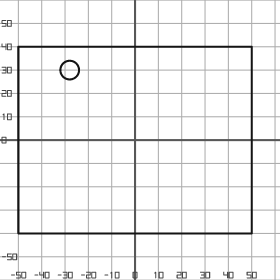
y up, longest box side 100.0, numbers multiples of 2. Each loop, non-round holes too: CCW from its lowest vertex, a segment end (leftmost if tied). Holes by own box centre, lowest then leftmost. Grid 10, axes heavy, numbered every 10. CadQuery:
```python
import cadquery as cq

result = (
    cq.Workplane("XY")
    .moveTo(-50.0, -40.0)
    .lineTo(50.0, -40.0)
    .lineTo(50.0, 40.0)
    .lineTo(-50.0, 40.0)
    .close()
    .moveTo(-28.0, 30.0)
    .circle(4.0)
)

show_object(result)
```